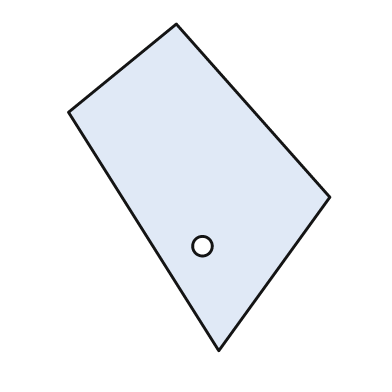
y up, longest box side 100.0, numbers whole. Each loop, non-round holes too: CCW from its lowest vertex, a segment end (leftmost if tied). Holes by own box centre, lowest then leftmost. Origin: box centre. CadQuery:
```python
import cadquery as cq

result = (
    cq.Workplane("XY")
    .moveTo(6.0, -50.0)
    .lineTo(40.0, -3.0)
    .lineTo(-7.0, 50.0)
    .lineTo(-40.0, 23.0)
    .close()
    .moveTo(1.0, -18.0)
    .circle(3.0)
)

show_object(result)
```